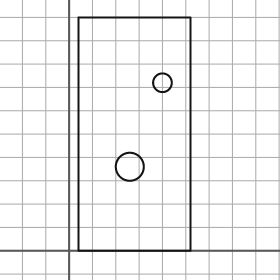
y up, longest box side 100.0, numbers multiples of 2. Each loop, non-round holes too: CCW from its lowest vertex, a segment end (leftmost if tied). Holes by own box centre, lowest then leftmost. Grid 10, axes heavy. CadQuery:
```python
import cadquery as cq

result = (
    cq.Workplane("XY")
    .moveTo(4.0, 0.0)
    .lineTo(52.0, 0.0)
    .lineTo(52.0, 100.0)
    .lineTo(4.0, 100.0)
    .close()
    .moveTo(26.0, 36.0)
    .circle(6.0)
    .moveTo(40.0, 72.0)
    .circle(4.0)
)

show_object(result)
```